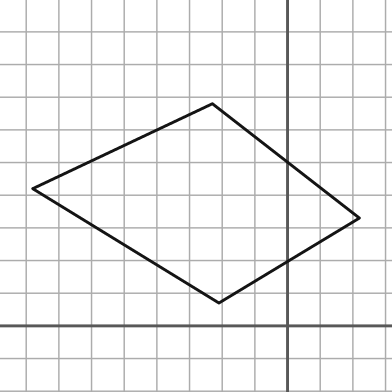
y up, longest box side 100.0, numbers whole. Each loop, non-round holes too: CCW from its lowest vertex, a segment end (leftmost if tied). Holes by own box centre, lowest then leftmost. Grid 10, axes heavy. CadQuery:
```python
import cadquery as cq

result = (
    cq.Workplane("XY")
    .moveTo(-21.0, 7.0)
    .lineTo(22.0, 33.0)
    .lineTo(-23.0, 68.0)
    .lineTo(-78.0, 42.0)
    .close()
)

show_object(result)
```